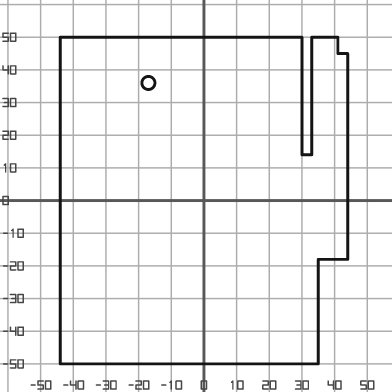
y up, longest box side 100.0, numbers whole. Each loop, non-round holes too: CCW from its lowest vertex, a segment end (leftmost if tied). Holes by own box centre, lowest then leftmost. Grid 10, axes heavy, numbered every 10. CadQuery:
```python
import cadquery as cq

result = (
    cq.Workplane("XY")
    .moveTo(-44.0, -50.0)
    .lineTo(35.0, -50.0)
    .lineTo(35.0, -18.0)
    .lineTo(44.0, -18.0)
    .lineTo(44.0, 45.0)
    .lineTo(41.0, 45.0)
    .lineTo(41.0, 50.0)
    .lineTo(33.0, 50.0)
    .lineTo(33.0, 14.0)
    .lineTo(30.0, 14.0)
    .lineTo(30.0, 50.0)
    .lineTo(-44.0, 50.0)
    .close()
    .moveTo(-17.0, 36.0)
    .circle(2.0)
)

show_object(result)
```